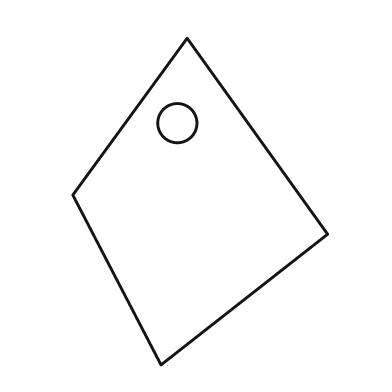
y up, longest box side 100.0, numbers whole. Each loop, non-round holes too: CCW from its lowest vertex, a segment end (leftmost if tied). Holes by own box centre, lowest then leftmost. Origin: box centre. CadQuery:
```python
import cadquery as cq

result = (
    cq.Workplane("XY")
    .moveTo(-12.0, -50.0)
    .lineTo(39.0, -10.0)
    .lineTo(-4.0, 50.0)
    .lineTo(-39.0, 2.0)
    .close()
    .moveTo(-7.0, 24.0)
    .circle(6.0)
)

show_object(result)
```